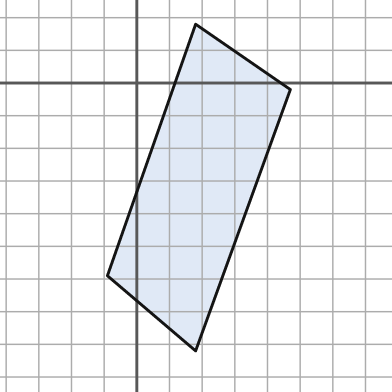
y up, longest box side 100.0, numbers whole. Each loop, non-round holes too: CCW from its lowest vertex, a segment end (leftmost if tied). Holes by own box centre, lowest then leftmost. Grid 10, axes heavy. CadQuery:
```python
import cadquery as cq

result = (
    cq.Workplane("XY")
    .moveTo(18.0, -82.0)
    .lineTo(47.0, -2.0)
    .lineTo(18.0, 18.0)
    .lineTo(-9.0, -59.0)
    .close()
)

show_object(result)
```